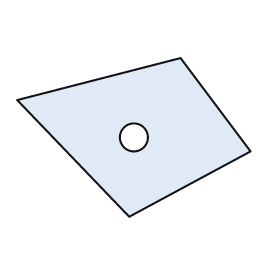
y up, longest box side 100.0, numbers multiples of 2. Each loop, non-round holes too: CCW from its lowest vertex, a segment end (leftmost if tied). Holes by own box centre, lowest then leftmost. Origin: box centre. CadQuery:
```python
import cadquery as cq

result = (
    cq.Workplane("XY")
    .moveTo(-2.0, -34.0)
    .lineTo(50.0, -6.0)
    .lineTo(20.0, 34.0)
    .lineTo(-50.0, 16.0)
    .close()
    .moveTo(0.0, 0.0)
    .circle(6.0)
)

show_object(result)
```